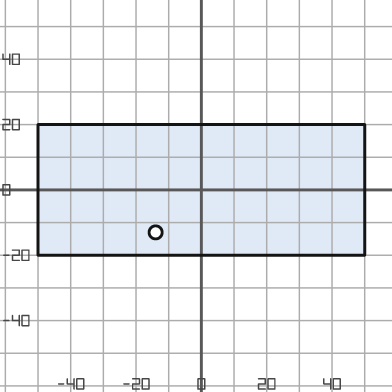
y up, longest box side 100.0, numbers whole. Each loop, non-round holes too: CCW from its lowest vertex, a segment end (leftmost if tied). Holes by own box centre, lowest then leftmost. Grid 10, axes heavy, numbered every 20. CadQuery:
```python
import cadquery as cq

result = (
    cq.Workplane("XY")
    .moveTo(-50.0, -20.0)
    .lineTo(50.0, -20.0)
    .lineTo(50.0, 20.0)
    .lineTo(-50.0, 20.0)
    .close()
    .moveTo(-14.0, -13.0)
    .circle(2.0)
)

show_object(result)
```